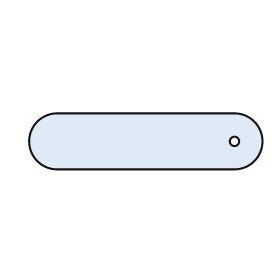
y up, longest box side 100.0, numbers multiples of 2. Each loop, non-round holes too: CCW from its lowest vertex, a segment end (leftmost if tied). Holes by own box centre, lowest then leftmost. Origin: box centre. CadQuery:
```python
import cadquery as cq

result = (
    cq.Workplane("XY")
    .moveTo(-38.0, -12.0)
    .lineTo(38.0, -12.0)
    .threePointArc((50.0, 0.0), (38.0, 12.0))
    .lineTo(-38.0, 12.0)
    .threePointArc((-50.0, 0.0), (-38.0, -12.0))
    .close()
    .moveTo(38.0, 0.0)
    .circle(2.0)
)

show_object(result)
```